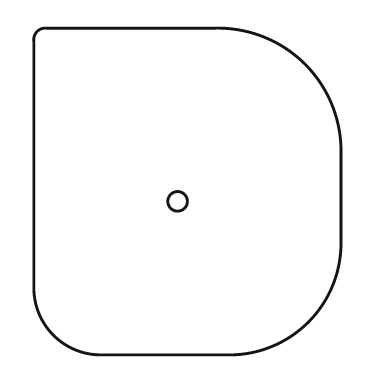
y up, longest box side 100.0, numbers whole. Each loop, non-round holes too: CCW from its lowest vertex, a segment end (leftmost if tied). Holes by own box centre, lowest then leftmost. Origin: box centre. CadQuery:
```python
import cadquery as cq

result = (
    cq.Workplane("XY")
    .moveTo(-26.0, -50.0)
    .lineTo(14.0, -50.0)
    .threePointArc((37.0, -40.0), (47.0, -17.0))
    .lineTo(47.0, 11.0)
    .threePointArc((36.0, 39.0), (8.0, 50.0))
    .lineTo(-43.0, 50.0)
    .threePointArc((-46.0, 49.0), (-47.0, 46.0))
    .lineTo(-47.0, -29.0)
    .threePointArc((-41.0, -44.0), (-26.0, -50.0))
    .close()
    .moveTo(-3.0, -3.0)
    .circle(3.0)
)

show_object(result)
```